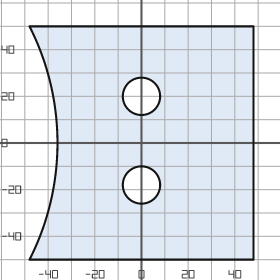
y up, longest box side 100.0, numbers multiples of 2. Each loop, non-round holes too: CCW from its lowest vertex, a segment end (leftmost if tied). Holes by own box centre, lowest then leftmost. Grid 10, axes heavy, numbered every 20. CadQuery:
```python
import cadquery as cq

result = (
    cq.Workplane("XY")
    .moveTo(-48.0, -50.0)
    .lineTo(48.0, -50.0)
    .lineTo(48.0, 50.0)
    .lineTo(-48.0, 50.0)
    .threePointArc((-36.0, 0.0), (-48.0, -50.0))
    .close()
    .moveTo(0.0, -18.0)
    .circle(8.0)
    .moveTo(0.0, 20.0)
    .circle(8.0)
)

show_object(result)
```